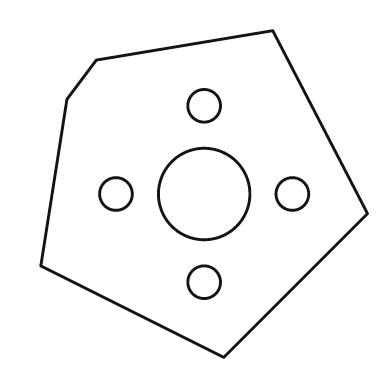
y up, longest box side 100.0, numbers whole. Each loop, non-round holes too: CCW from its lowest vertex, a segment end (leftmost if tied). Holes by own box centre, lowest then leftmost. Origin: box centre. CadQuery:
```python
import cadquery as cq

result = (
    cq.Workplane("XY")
    .moveTo(6.0, -50.0)
    .lineTo(50.0, -6.0)
    .lineTo(21.0, 50.0)
    .lineTo(-33.0, 41.0)
    .lineTo(-42.0, 29.0)
    .lineTo(-50.0, -22.0)
    .close()
    .moveTo(0.0, -27.0)
    .circle(5.0)
    .moveTo(-27.0, 0.0)
    .circle(5.0)
    .moveTo(0.0, 0.0)
    .circle(14.0)
    .moveTo(27.0, 0.0)
    .circle(5.0)
    .moveTo(0.0, 27.0)
    .circle(5.0)
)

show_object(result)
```